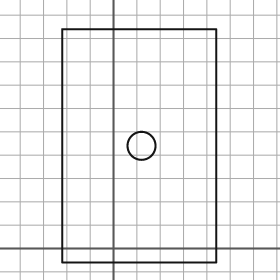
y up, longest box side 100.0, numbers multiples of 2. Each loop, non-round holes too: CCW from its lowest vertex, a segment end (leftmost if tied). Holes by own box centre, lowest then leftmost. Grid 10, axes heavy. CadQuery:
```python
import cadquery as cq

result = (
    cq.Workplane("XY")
    .moveTo(-22.0, -6.0)
    .lineTo(44.0, -6.0)
    .lineTo(44.0, 94.0)
    .lineTo(-22.0, 94.0)
    .close()
    .moveTo(12.0, 44.0)
    .circle(6.0)
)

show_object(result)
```